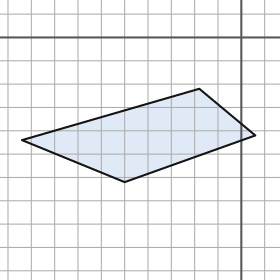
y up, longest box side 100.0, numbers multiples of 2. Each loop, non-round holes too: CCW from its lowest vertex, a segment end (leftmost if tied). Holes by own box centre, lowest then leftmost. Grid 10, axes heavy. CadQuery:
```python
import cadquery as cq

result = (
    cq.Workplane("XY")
    .moveTo(-50.0, -62.0)
    .lineTo(6.0, -42.0)
    .lineTo(-18.0, -22.0)
    .lineTo(-94.0, -44.0)
    .close()
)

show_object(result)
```